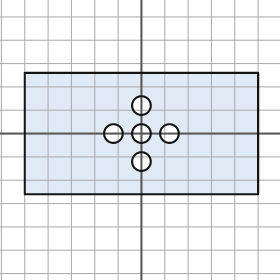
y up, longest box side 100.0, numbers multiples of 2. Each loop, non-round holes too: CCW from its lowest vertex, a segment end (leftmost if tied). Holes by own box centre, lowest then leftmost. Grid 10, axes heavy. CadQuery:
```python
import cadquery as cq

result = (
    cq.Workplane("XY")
    .moveTo(-50.0, -26.0)
    .lineTo(50.0, -26.0)
    .lineTo(50.0, 26.0)
    .lineTo(-50.0, 26.0)
    .close()
    .moveTo(0.0, -12.0)
    .circle(4.0)
    .moveTo(-12.0, 0.0)
    .circle(4.0)
    .moveTo(0.0, 0.0)
    .circle(4.0)
    .moveTo(12.0, 0.0)
    .circle(4.0)
    .moveTo(0.0, 12.0)
    .circle(4.0)
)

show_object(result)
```